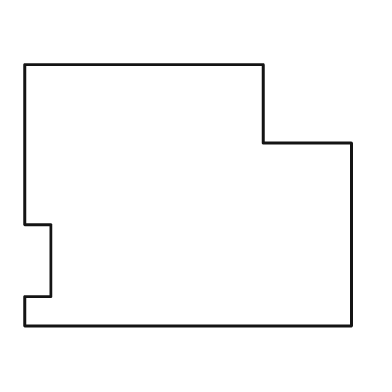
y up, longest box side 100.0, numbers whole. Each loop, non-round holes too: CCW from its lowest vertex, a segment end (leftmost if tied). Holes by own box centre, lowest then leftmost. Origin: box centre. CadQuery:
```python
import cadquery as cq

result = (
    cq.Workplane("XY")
    .moveTo(-50.0, -40.0)
    .lineTo(50.0, -40.0)
    .lineTo(50.0, 16.0)
    .lineTo(23.0, 16.0)
    .lineTo(23.0, 40.0)
    .lineTo(-50.0, 40.0)
    .lineTo(-50.0, -9.0)
    .lineTo(-42.0, -9.0)
    .lineTo(-42.0, -31.0)
    .lineTo(-50.0, -31.0)
    .close()
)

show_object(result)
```